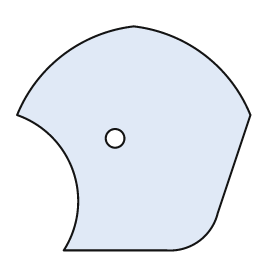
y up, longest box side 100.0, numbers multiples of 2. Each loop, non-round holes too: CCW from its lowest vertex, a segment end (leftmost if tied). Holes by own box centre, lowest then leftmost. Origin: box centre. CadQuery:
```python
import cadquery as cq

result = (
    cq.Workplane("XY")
    .moveTo(-30.0, -48.0)
    .lineTo(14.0, -48.0)
    .threePointArc((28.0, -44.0), (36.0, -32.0))
    .lineTo(50.0, 10.0)
    .threePointArc((30.0, 36.0), (0.0, 48.0))
    .threePointArc((-30.0, 36.0), (-50.0, 10.0))
    .threePointArc((-26.0, -14.0), (-30.0, -48.0))
    .close()
    .moveTo(-8.0, 0.0)
    .circle(4.0)
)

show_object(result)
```